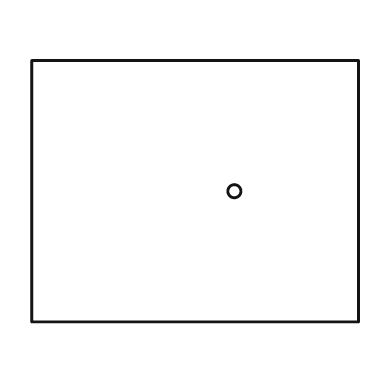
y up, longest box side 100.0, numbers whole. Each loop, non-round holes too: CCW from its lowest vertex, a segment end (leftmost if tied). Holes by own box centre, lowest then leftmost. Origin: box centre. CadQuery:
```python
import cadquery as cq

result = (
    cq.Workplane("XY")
    .moveTo(-50.0, -40.0)
    .lineTo(50.0, -40.0)
    .lineTo(50.0, 40.0)
    .lineTo(-50.0, 40.0)
    .close()
    .moveTo(12.0, 0.0)
    .circle(2.0)
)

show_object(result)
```